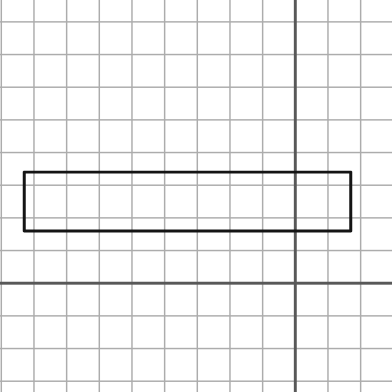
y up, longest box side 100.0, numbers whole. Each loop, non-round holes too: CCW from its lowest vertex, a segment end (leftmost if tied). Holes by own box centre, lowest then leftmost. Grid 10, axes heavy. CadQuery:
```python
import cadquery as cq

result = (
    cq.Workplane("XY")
    .moveTo(-83.0, 16.0)
    .lineTo(17.0, 16.0)
    .lineTo(17.0, 34.0)
    .lineTo(-83.0, 34.0)
    .close()
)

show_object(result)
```